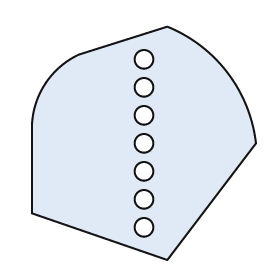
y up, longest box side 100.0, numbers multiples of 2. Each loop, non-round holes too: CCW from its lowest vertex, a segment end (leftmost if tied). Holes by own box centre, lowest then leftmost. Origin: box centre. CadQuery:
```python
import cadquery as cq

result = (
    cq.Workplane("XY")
    .moveTo(10.0, -50.0)
    .lineTo(48.0, 0.0)
    .threePointArc((36.0, 30.0), (10.0, 50.0))
    .lineTo(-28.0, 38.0)
    .threePointArc((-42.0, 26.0), (-48.0, 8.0))
    .lineTo(-48.0, -30.0)
    .close()
    .moveTo(0.0, -36.0)
    .circle(4.0)
    .moveTo(0.0, -24.0)
    .circle(4.0)
    .moveTo(0.0, -12.0)
    .circle(4.0)
    .moveTo(0.0, 0.0)
    .circle(4.0)
    .moveTo(0.0, 12.0)
    .circle(4.0)
    .moveTo(0.0, 24.0)
    .circle(4.0)
    .moveTo(0.0, 36.0)
    .circle(4.0)
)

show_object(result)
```